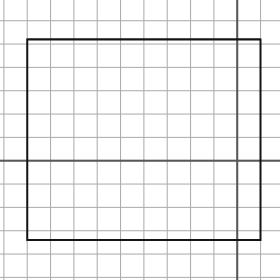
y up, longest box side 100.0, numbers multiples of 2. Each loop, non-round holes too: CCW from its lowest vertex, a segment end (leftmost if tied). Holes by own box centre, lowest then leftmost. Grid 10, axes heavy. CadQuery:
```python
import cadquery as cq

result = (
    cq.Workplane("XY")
    .moveTo(-90.0, -34.0)
    .lineTo(10.0, -34.0)
    .lineTo(10.0, 52.0)
    .lineTo(-90.0, 52.0)
    .close()
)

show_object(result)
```